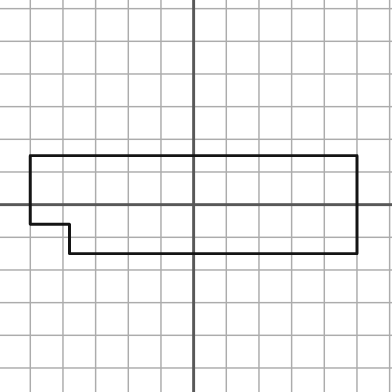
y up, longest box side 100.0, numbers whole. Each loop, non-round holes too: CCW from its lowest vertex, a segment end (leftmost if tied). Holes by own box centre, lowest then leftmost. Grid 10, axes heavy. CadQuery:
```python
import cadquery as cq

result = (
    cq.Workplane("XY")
    .moveTo(-38.0, -15.0)
    .lineTo(50.0, -15.0)
    .lineTo(50.0, 15.0)
    .lineTo(-50.0, 15.0)
    .lineTo(-50.0, -6.0)
    .lineTo(-38.0, -6.0)
    .close()
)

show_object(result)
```